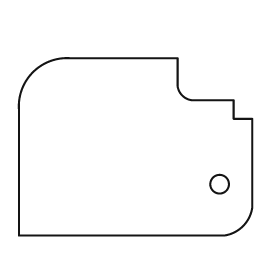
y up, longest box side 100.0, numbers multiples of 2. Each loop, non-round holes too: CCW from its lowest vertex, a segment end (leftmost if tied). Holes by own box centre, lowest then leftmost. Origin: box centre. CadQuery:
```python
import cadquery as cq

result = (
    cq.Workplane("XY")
    .moveTo(-50.0, -38.0)
    .lineTo(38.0, -38.0)
    .threePointArc((46.0, -34.0), (50.0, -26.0))
    .lineTo(50.0, 12.0)
    .lineTo(42.0, 12.0)
    .lineTo(42.0, 20.0)
    .lineTo(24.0, 20.0)
    .threePointArc((20.0, 22.0), (18.0, 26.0))
    .lineTo(18.0, 38.0)
    .lineTo(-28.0, 38.0)
    .threePointArc((-44.0, 32.0), (-50.0, 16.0))
    .close()
    .moveTo(36.0, -16.0)
    .circle(4.0)
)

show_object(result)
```